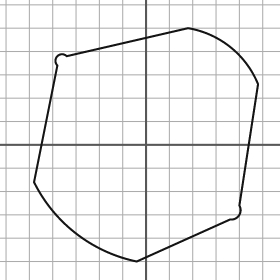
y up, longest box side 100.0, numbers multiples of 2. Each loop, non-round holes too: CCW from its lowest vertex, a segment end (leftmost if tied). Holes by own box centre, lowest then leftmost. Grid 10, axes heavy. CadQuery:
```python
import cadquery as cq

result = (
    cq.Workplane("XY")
    .moveTo(-4.0, -50.0)
    .lineTo(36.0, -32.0)
    .threePointArc((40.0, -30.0), (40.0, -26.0))
    .lineTo(48.0, 26.0)
    .threePointArc((36.0, 42.0), (18.0, 50.0))
    .lineTo(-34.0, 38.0)
    .threePointArc((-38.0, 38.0), (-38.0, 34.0))
    .lineTo(-48.0, -16.0)
    .threePointArc((-30.0, -38.0), (-4.0, -50.0))
    .close()
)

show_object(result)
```